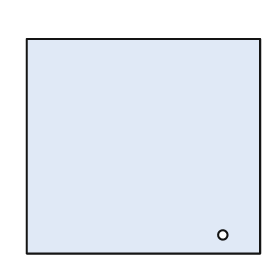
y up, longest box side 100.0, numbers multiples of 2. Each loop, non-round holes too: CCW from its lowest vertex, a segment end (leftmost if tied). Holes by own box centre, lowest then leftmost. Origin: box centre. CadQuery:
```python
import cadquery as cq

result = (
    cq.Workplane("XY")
    .moveTo(-50.0, -46.0)
    .lineTo(50.0, -46.0)
    .lineTo(50.0, 46.0)
    .lineTo(-50.0, 46.0)
    .close()
    .moveTo(34.0, -38.0)
    .circle(2.0)
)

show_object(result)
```